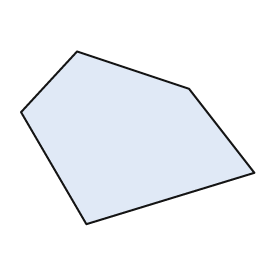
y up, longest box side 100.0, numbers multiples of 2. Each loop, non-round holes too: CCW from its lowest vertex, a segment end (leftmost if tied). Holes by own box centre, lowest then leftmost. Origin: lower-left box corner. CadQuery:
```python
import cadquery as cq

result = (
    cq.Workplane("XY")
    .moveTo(28.0, 0.0)
    .lineTo(100.0, 22.0)
    .lineTo(72.0, 58.0)
    .lineTo(24.0, 74.0)
    .lineTo(0.0, 48.0)
    .close()
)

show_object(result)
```